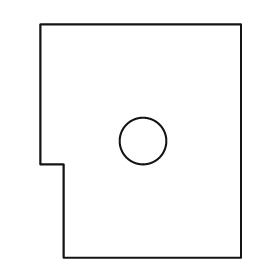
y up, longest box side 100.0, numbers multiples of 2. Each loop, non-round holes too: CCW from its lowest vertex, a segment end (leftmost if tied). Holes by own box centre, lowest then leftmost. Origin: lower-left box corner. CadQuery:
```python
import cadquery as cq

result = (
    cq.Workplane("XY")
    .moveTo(10.0, 0.0)
    .lineTo(86.0, 0.0)
    .lineTo(86.0, 100.0)
    .lineTo(0.0, 100.0)
    .lineTo(0.0, 40.0)
    .lineTo(10.0, 40.0)
    .close()
    .moveTo(44.0, 50.0)
    .circle(10.0)
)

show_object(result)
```